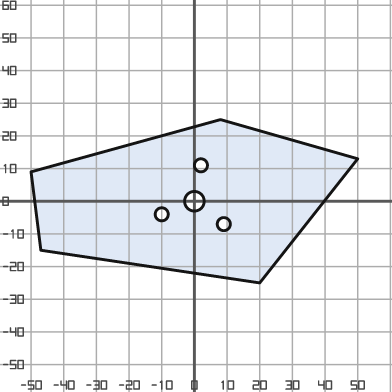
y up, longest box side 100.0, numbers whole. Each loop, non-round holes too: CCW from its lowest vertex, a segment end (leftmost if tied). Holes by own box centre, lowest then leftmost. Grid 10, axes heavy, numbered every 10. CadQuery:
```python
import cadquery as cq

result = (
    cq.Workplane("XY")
    .moveTo(20.0, -25.0)
    .lineTo(50.0, 13.0)
    .lineTo(8.0, 25.0)
    .lineTo(-50.0, 9.0)
    .lineTo(-47.0, -15.0)
    .close()
    .moveTo(9.0, -7.0)
    .circle(2.0)
    .moveTo(-10.0, -4.0)
    .circle(2.0)
    .moveTo(0.0, 0.0)
    .circle(3.0)
    .moveTo(2.0, 11.0)
    .circle(2.0)
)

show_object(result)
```